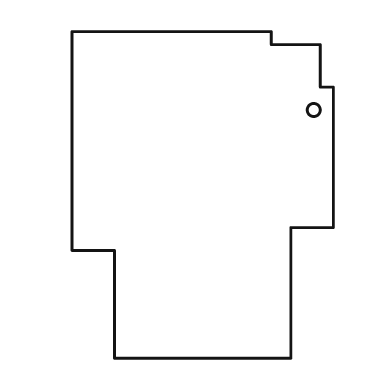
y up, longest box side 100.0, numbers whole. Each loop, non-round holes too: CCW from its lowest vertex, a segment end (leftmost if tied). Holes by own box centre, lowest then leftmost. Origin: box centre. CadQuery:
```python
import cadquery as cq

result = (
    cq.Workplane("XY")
    .moveTo(-27.0, -50.0)
    .lineTo(27.0, -50.0)
    .lineTo(27.0, -10.0)
    .lineTo(40.0, -10.0)
    .lineTo(40.0, 33.0)
    .lineTo(36.0, 33.0)
    .lineTo(36.0, 46.0)
    .lineTo(21.0, 46.0)
    .lineTo(21.0, 50.0)
    .lineTo(-40.0, 50.0)
    .lineTo(-40.0, -17.0)
    .lineTo(-27.0, -17.0)
    .close()
    .moveTo(34.0, 26.0)
    .circle(2.0)
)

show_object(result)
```